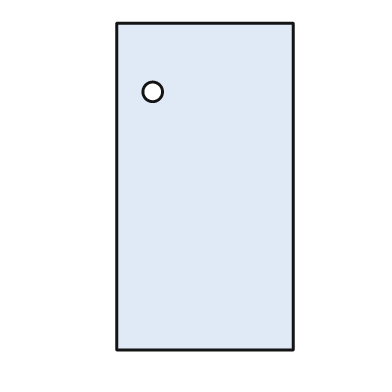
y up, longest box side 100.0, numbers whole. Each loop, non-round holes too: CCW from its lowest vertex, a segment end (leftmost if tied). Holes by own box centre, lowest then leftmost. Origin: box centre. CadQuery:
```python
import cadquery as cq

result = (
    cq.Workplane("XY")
    .moveTo(-27.0, -50.0)
    .lineTo(27.0, -50.0)
    .lineTo(27.0, 50.0)
    .lineTo(-27.0, 50.0)
    .close()
    .moveTo(-16.0, 29.0)
    .circle(3.0)
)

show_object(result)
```